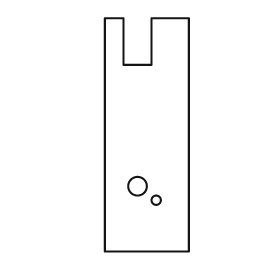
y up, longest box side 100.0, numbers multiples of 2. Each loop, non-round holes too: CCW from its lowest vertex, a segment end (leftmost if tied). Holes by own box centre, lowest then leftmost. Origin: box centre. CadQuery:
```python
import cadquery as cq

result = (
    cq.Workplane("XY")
    .moveTo(-18.0, -50.0)
    .lineTo(18.0, -50.0)
    .lineTo(18.0, 50.0)
    .lineTo(2.0, 50.0)
    .lineTo(2.0, 30.0)
    .lineTo(-10.0, 30.0)
    .lineTo(-10.0, 50.0)
    .lineTo(-18.0, 50.0)
    .close()
    .moveTo(4.0, -28.0)
    .circle(2.0)
    .moveTo(-4.0, -22.0)
    .circle(4.0)
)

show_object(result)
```